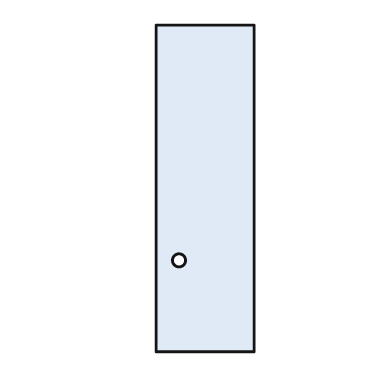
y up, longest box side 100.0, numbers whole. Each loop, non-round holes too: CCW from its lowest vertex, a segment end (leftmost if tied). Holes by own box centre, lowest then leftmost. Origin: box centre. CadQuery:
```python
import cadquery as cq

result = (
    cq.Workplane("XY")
    .moveTo(-15.0, -50.0)
    .lineTo(15.0, -50.0)
    .lineTo(15.0, 50.0)
    .lineTo(-15.0, 50.0)
    .close()
    .moveTo(-8.0, -22.0)
    .circle(2.0)
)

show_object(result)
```